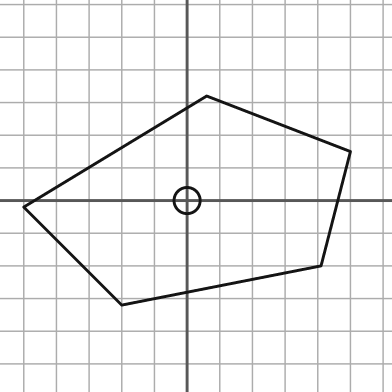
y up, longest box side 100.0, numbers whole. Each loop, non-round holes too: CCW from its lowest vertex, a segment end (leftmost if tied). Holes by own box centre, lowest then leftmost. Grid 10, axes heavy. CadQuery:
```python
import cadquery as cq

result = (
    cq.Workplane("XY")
    .moveTo(-20.0, -32.0)
    .lineTo(41.0, -20.0)
    .lineTo(50.0, 15.0)
    .lineTo(6.0, 32.0)
    .lineTo(-50.0, -2.0)
    .close()
    .moveTo(0.0, 0.0)
    .circle(4.0)
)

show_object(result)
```